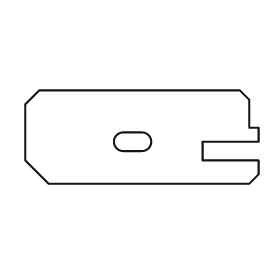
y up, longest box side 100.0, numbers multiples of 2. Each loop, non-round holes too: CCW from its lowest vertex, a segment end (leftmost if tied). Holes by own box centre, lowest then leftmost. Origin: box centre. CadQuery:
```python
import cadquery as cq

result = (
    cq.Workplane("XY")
    .moveTo(-40.0, -20.0)
    .lineTo(46.0, -20.0)
    .lineTo(50.0, -16.0)
    .lineTo(50.0, -10.0)
    .lineTo(26.0, -10.0)
    .lineTo(26.0, -2.0)
    .lineTo(50.0, -2.0)
    .lineTo(50.0, 4.0)
    .lineTo(46.0, 4.0)
    .lineTo(46.0, 16.0)
    .lineTo(42.0, 20.0)
    .lineTo(-44.0, 20.0)
    .lineTo(-50.0, 14.0)
    .lineTo(-50.0, -10.0)
    .close()
    .moveTo(-8.0, -6.0)
    .lineTo(0.0, -6.0)
    .threePointArc((4.0, -2.0), (0.0, 2.0))
    .lineTo(-8.0, 2.0)
    .threePointArc((-12.0, -2.0), (-8.0, -6.0))
    .close()
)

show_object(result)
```